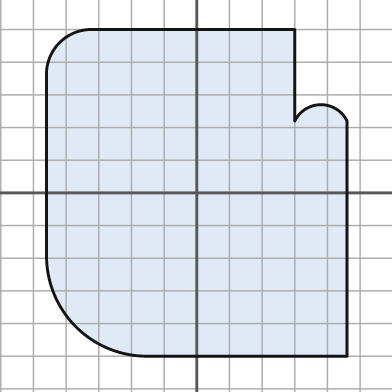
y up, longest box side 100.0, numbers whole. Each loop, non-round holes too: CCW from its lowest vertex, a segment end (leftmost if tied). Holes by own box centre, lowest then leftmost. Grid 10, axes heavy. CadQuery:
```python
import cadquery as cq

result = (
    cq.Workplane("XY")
    .moveTo(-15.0, -50.0)
    .lineTo(46.0, -50.0)
    .lineTo(46.0, 22.0)
    .threePointArc((38.0, 27.0), (30.0, 22.0))
    .lineTo(30.0, 50.0)
    .lineTo(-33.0, 50.0)
    .threePointArc((-42.0, 46.0), (-46.0, 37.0))
    .lineTo(-46.0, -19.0)
    .threePointArc((-37.0, -41.0), (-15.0, -50.0))
    .close()
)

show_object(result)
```